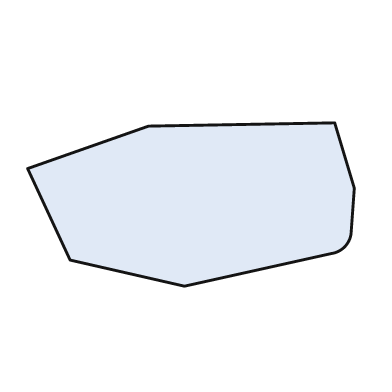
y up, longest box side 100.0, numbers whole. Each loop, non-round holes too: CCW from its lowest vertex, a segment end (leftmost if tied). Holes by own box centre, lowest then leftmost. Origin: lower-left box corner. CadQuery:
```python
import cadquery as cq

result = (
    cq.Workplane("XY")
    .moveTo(48.0, 0.0)
    .lineTo(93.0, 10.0)
    .threePointArc((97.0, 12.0), (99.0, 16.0))
    .lineTo(100.0, 30.0)
    .lineTo(94.0, 50.0)
    .lineTo(37.0, 49.0)
    .lineTo(0.0, 36.0)
    .lineTo(13.0, 8.0)
    .close()
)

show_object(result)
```